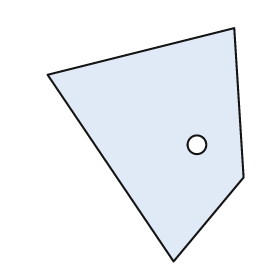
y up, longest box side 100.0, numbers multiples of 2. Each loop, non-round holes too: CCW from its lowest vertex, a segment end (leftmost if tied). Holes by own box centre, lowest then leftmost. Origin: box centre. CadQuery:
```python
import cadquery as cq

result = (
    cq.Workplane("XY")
    .moveTo(12.0, -50.0)
    .lineTo(42.0, -14.0)
    .lineTo(38.0, 50.0)
    .lineTo(-42.0, 30.0)
    .close()
    .moveTo(22.0, 0.0)
    .circle(4.0)
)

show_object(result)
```